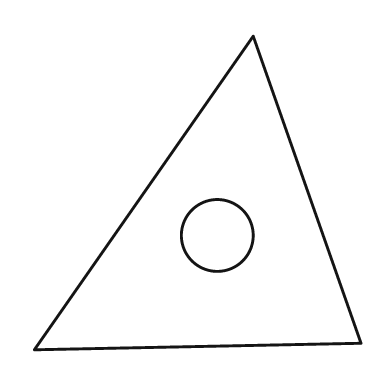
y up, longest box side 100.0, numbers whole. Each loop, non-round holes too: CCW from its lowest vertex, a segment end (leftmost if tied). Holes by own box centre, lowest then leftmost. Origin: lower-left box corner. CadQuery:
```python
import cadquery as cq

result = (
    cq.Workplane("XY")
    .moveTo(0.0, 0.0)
    .lineTo(100.0, 2.0)
    .lineTo(67.0, 96.0)
    .close()
    .moveTo(56.0, 35.0)
    .circle(11.0)
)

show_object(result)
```